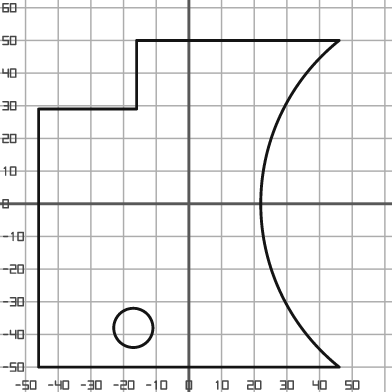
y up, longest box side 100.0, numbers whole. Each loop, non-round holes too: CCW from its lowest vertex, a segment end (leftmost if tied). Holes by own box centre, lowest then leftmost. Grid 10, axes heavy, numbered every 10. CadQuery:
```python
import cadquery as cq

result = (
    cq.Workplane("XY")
    .moveTo(-46.0, -50.0)
    .lineTo(46.0, -50.0)
    .threePointArc((22.0, 0.0), (46.0, 50.0))
    .lineTo(-16.0, 50.0)
    .lineTo(-16.0, 29.0)
    .lineTo(-46.0, 29.0)
    .close()
    .moveTo(-17.0, -38.0)
    .circle(6.0)
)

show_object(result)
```